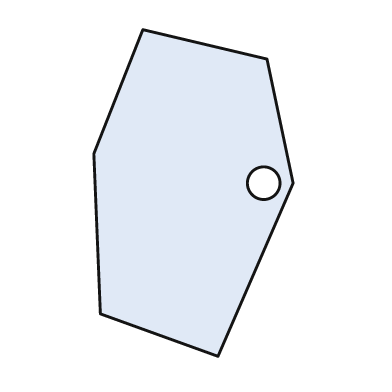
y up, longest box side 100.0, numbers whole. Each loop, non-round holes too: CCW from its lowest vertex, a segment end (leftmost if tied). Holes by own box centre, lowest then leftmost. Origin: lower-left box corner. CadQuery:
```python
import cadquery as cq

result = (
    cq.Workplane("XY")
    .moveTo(38.0, 0.0)
    .lineTo(61.0, 53.0)
    .lineTo(53.0, 91.0)
    .lineTo(15.0, 100.0)
    .lineTo(0.0, 62.0)
    .lineTo(2.0, 13.0)
    .close()
    .moveTo(52.0, 53.0)
    .circle(5.0)
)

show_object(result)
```